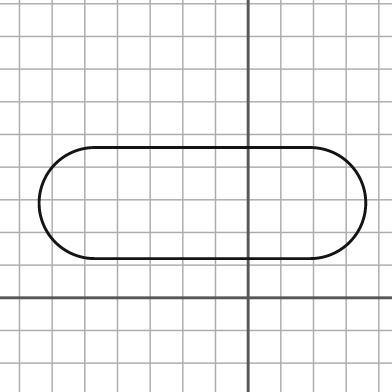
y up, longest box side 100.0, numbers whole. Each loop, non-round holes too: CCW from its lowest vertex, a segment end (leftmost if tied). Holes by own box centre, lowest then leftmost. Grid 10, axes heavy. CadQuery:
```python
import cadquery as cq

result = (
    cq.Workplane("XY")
    .moveTo(-47.0, 12.0)
    .lineTo(19.0, 12.0)
    .threePointArc((36.0, 29.0), (19.0, 46.0))
    .lineTo(-47.0, 46.0)
    .threePointArc((-64.0, 29.0), (-47.0, 12.0))
    .close()
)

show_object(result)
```